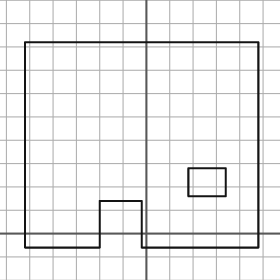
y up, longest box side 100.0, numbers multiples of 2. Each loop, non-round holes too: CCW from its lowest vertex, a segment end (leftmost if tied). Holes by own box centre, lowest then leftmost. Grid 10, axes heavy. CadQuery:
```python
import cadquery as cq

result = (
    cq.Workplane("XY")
    .moveTo(-52.0, -6.0)
    .lineTo(-20.0, -6.0)
    .lineTo(-20.0, 14.0)
    .lineTo(-2.0, 14.0)
    .lineTo(-2.0, -6.0)
    .lineTo(48.0, -6.0)
    .lineTo(48.0, 82.0)
    .lineTo(-52.0, 82.0)
    .close()
    .moveTo(18.0, 16.0)
    .lineTo(34.0, 16.0)
    .lineTo(34.0, 28.0)
    .lineTo(18.0, 28.0)
    .close()
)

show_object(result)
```